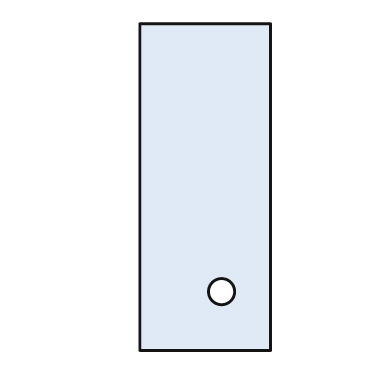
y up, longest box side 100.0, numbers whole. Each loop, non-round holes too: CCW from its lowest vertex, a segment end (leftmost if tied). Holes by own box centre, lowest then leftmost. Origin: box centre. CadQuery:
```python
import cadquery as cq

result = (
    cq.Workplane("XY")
    .moveTo(-20.0, -50.0)
    .lineTo(20.0, -50.0)
    .lineTo(20.0, 50.0)
    .lineTo(-20.0, 50.0)
    .close()
    .moveTo(5.0, -32.0)
    .circle(4.0)
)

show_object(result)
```